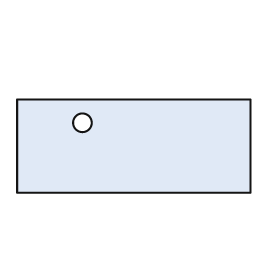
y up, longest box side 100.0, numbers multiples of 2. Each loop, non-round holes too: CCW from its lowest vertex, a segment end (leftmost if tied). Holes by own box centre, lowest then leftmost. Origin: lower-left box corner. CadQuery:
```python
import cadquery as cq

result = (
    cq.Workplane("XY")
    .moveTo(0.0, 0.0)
    .lineTo(100.0, 0.0)
    .lineTo(100.0, 40.0)
    .lineTo(0.0, 40.0)
    .close()
    .moveTo(28.0, 30.0)
    .circle(4.0)
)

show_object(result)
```